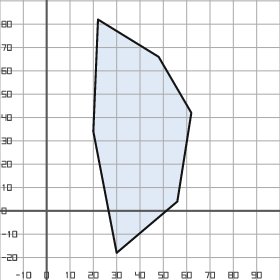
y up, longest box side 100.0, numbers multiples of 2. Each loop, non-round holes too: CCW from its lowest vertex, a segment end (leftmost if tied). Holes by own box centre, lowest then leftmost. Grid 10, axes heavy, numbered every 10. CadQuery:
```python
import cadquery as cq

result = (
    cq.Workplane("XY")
    .moveTo(30.0, -18.0)
    .lineTo(56.0, 4.0)
    .lineTo(62.0, 42.0)
    .lineTo(48.0, 66.0)
    .lineTo(22.0, 82.0)
    .lineTo(20.0, 34.0)
    .close()
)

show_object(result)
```